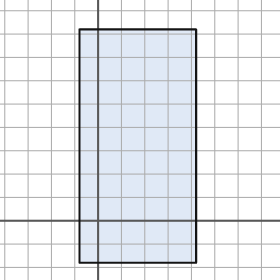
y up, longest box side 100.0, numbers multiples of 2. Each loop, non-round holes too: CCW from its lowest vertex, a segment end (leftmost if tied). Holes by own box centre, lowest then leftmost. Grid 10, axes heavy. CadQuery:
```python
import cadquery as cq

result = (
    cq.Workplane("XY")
    .moveTo(-8.0, -18.0)
    .lineTo(42.0, -18.0)
    .lineTo(42.0, 82.0)
    .lineTo(-8.0, 82.0)
    .close()
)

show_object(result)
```